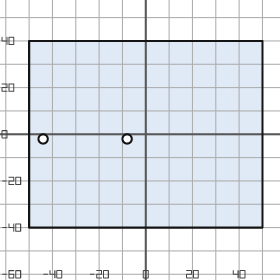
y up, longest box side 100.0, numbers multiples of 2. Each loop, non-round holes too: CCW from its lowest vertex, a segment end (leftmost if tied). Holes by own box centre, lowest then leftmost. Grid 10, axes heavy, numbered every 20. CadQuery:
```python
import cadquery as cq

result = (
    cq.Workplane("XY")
    .moveTo(-50.0, -40.0)
    .lineTo(50.0, -40.0)
    .lineTo(50.0, 40.0)
    .lineTo(-50.0, 40.0)
    .close()
    .moveTo(-44.0, -2.0)
    .circle(2.0)
    .moveTo(-8.0, -2.0)
    .circle(2.0)
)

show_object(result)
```